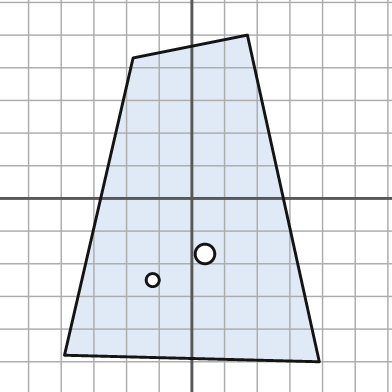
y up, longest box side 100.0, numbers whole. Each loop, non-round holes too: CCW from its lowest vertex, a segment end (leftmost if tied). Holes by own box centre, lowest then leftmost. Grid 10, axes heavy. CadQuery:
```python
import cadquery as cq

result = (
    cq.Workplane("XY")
    .moveTo(39.0, -50.0)
    .lineTo(17.0, 50.0)
    .lineTo(-18.0, 43.0)
    .lineTo(-39.0, -48.0)
    .close()
    .moveTo(-12.0, -25.0)
    .circle(2.0)
    .moveTo(4.0, -17.0)
    .circle(3.0)
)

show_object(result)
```